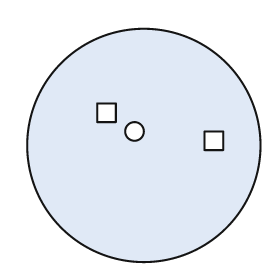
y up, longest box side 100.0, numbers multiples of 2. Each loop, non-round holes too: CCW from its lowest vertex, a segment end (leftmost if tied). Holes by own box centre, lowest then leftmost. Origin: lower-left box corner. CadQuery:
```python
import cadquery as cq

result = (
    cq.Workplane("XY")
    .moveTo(50.0, 50.0)
    .circle(50.0)
    .moveTo(76.0, 48.0)
    .lineTo(84.0, 48.0)
    .lineTo(84.0, 56.0)
    .lineTo(76.0, 56.0)
    .close()
    .moveTo(46.0, 56.0)
    .circle(4.0)
    .moveTo(30.0, 60.0)
    .lineTo(38.0, 60.0)
    .lineTo(38.0, 68.0)
    .lineTo(30.0, 68.0)
    .close()
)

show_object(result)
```